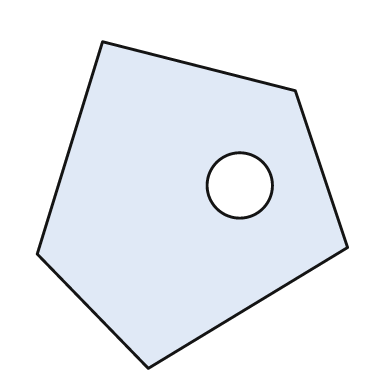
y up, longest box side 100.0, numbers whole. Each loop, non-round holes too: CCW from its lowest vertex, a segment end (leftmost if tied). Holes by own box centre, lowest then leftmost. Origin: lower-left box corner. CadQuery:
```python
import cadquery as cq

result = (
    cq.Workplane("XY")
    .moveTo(34.0, 0.0)
    .lineTo(95.0, 37.0)
    .lineTo(79.0, 85.0)
    .lineTo(20.0, 100.0)
    .lineTo(0.0, 35.0)
    .close()
    .moveTo(62.0, 56.0)
    .circle(10.0)
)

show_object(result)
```